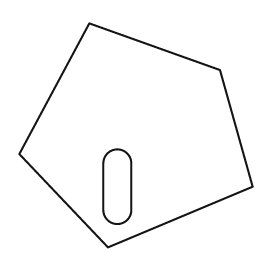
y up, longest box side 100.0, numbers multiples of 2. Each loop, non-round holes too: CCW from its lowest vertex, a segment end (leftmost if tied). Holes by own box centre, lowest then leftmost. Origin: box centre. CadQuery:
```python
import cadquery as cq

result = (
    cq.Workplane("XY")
    .moveTo(-12.0, -48.0)
    .lineTo(50.0, -22.0)
    .lineTo(36.0, 28.0)
    .lineTo(-20.0, 48.0)
    .lineTo(-50.0, -8.0)
    .close()
    .moveTo(-14.0, -32.0)
    .threePointArc((-8.0, -38.0), (-2.0, -32.0))
    .lineTo(-2.0, -12.0)
    .threePointArc((-8.0, -6.0), (-14.0, -12.0))
    .close()
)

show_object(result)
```